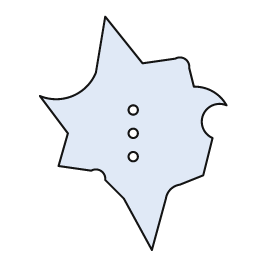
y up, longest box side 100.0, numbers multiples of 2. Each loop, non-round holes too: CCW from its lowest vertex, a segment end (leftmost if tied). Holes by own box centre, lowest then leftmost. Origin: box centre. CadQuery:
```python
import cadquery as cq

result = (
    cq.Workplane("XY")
    .moveTo(8.0, -50.0)
    .lineTo(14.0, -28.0)
    .threePointArc((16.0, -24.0), (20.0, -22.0))
    .lineTo(30.0, -18.0)
    .lineTo(34.0, -2.0)
    .threePointArc((30.0, 8.0), (40.0, 12.0))
    .threePointArc((34.0, 18.0), (26.0, 20.0))
    .lineTo(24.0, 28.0)
    .threePointArc((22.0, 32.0), (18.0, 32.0))
    .lineTo(4.0, 30.0)
    .lineTo(-12.0, 50.0)
    .lineTo(-16.0, 26.0)
    .threePointArc((-26.0, 16.0), (-40.0, 16.0))
    .lineTo(-28.0, 0.0)
    .lineTo(-32.0, -14.0)
    .lineTo(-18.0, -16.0)
    .threePointArc((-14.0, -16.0), (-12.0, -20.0))
    .lineTo(-4.0, -28.0)
    .close()
    .moveTo(0.0, -10.0)
    .circle(2.0)
    .moveTo(0.0, 0.0)
    .circle(2.0)
    .moveTo(0.0, 10.0)
    .circle(2.0)
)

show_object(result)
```